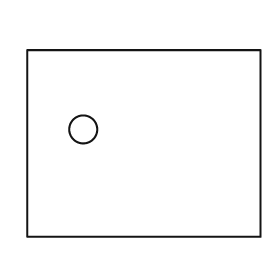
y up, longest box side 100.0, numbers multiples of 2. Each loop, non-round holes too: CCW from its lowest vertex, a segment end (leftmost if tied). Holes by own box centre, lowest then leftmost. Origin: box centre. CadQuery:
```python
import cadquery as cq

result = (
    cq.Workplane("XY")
    .moveTo(-50.0, -40.0)
    .lineTo(50.0, -40.0)
    .lineTo(50.0, 40.0)
    .lineTo(-50.0, 40.0)
    .close()
    .moveTo(-26.0, 6.0)
    .circle(6.0)
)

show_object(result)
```